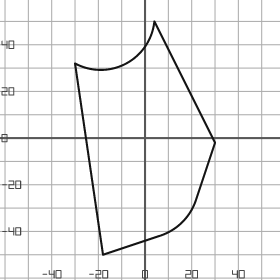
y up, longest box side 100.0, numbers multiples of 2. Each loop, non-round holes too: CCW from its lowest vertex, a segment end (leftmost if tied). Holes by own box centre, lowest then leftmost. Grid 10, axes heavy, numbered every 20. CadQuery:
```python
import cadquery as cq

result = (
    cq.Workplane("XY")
    .moveTo(-18.0, -50.0)
    .lineTo(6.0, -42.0)
    .threePointArc((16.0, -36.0), (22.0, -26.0))
    .lineTo(30.0, -2.0)
    .lineTo(4.0, 50.0)
    .threePointArc((-8.0, 32.0), (-30.0, 32.0))
    .close()
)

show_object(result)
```